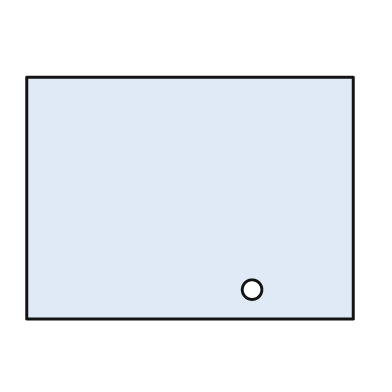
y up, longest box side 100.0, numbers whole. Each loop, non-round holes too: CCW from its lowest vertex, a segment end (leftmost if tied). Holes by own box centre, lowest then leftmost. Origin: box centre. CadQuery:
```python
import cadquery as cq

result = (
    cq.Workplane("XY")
    .moveTo(-50.0, -37.0)
    .lineTo(50.0, -37.0)
    .lineTo(50.0, 37.0)
    .lineTo(-50.0, 37.0)
    .close()
    .moveTo(19.0, -28.0)
    .circle(3.0)
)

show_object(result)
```